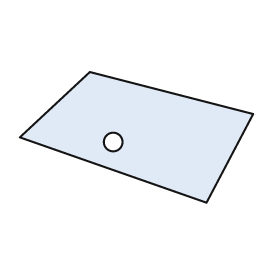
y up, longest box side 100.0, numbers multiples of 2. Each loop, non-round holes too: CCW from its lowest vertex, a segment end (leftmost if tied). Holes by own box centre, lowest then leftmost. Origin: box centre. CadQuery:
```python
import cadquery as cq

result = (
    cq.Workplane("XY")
    .moveTo(30.0, -28.0)
    .lineTo(50.0, 10.0)
    .lineTo(-20.0, 28.0)
    .lineTo(-50.0, 0.0)
    .close()
    .moveTo(-10.0, -2.0)
    .circle(4.0)
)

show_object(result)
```